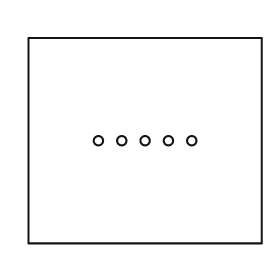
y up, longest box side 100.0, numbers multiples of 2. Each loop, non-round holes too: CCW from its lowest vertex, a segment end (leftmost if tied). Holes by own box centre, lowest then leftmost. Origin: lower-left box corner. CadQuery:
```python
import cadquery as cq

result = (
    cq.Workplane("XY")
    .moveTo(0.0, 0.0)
    .lineTo(100.0, 0.0)
    .lineTo(100.0, 88.0)
    .lineTo(0.0, 88.0)
    .close()
    .moveTo(30.0, 44.0)
    .circle(2.0)
    .moveTo(40.0, 44.0)
    .circle(2.0)
    .moveTo(50.0, 44.0)
    .circle(2.0)
    .moveTo(60.0, 44.0)
    .circle(2.0)
    .moveTo(70.0, 44.0)
    .circle(2.0)
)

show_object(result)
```